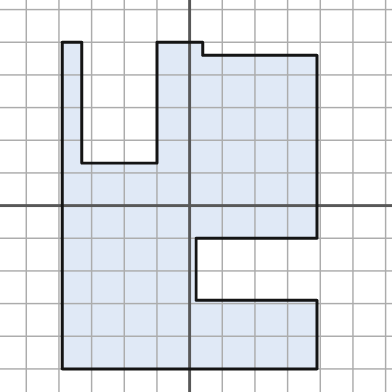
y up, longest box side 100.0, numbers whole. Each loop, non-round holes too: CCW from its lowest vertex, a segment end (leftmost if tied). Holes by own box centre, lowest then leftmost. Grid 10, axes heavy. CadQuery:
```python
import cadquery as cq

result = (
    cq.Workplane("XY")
    .moveTo(-39.0, -50.0)
    .lineTo(39.0, -50.0)
    .lineTo(39.0, -29.0)
    .lineTo(2.0, -29.0)
    .lineTo(2.0, -10.0)
    .lineTo(39.0, -10.0)
    .lineTo(39.0, 46.0)
    .lineTo(4.0, 46.0)
    .lineTo(4.0, 50.0)
    .lineTo(-10.0, 50.0)
    .lineTo(-10.0, 13.0)
    .lineTo(-33.0, 13.0)
    .lineTo(-33.0, 50.0)
    .lineTo(-39.0, 50.0)
    .close()
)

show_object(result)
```